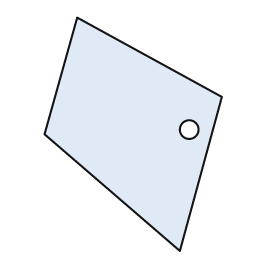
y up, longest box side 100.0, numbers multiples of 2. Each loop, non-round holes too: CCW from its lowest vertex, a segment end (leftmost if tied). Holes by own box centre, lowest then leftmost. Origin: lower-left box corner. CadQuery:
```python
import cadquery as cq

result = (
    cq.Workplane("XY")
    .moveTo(58.0, 0.0)
    .lineTo(76.0, 66.0)
    .lineTo(14.0, 100.0)
    .lineTo(0.0, 50.0)
    .close()
    .moveTo(62.0, 52.0)
    .circle(4.0)
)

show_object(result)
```